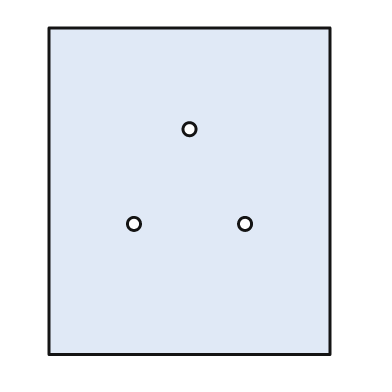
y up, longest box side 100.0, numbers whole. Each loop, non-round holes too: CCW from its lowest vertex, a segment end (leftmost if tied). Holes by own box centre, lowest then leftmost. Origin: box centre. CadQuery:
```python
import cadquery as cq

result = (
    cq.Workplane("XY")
    .moveTo(-43.0, -50.0)
    .lineTo(43.0, -50.0)
    .lineTo(43.0, 50.0)
    .lineTo(-43.0, 50.0)
    .close()
    .moveTo(-17.0, -10.0)
    .circle(2.0)
    .moveTo(17.0, -10.0)
    .circle(2.0)
    .moveTo(0.0, 19.0)
    .circle(2.0)
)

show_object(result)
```